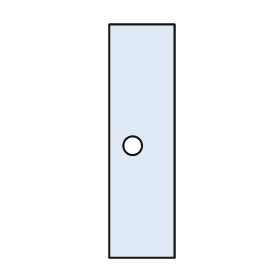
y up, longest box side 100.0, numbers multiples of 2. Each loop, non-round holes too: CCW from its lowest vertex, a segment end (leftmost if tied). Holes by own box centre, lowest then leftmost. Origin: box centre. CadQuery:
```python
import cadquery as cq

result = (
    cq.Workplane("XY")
    .moveTo(-14.0, -50.0)
    .lineTo(14.0, -50.0)
    .lineTo(14.0, 50.0)
    .lineTo(-14.0, 50.0)
    .close()
    .moveTo(-4.0, -2.0)
    .circle(4.0)
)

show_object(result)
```